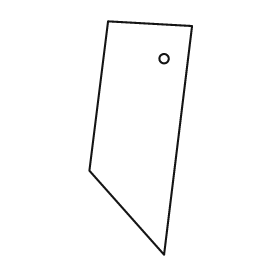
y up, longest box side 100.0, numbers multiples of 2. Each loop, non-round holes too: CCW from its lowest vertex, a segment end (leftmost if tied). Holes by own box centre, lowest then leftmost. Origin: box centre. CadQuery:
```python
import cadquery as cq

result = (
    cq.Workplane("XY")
    .moveTo(10.0, -50.0)
    .lineTo(22.0, 48.0)
    .lineTo(-14.0, 50.0)
    .lineTo(-22.0, -14.0)
    .close()
    .moveTo(10.0, 34.0)
    .circle(2.0)
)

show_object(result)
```